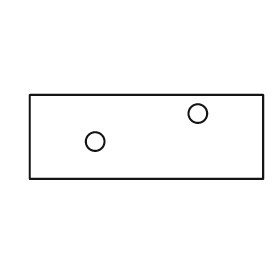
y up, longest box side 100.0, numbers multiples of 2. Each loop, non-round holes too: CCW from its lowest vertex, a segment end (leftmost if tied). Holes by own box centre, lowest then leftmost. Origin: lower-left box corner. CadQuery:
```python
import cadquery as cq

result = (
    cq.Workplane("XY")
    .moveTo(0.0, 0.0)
    .lineTo(100.0, 0.0)
    .lineTo(100.0, 36.0)
    .lineTo(0.0, 36.0)
    .close()
    .moveTo(28.0, 16.0)
    .circle(4.0)
    .moveTo(72.0, 28.0)
    .circle(4.0)
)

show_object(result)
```